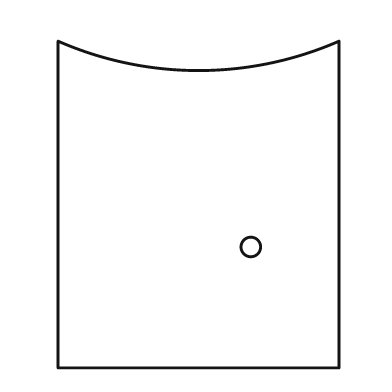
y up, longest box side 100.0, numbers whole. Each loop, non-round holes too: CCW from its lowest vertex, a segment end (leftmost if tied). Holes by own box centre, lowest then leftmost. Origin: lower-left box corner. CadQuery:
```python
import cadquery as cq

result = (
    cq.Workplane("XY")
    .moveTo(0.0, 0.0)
    .lineTo(86.0, 0.0)
    .lineTo(86.0, 100.0)
    .threePointArc((43.0, 91.0), (0.0, 100.0))
    .close()
    .moveTo(59.0, 37.0)
    .circle(3.0)
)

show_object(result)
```